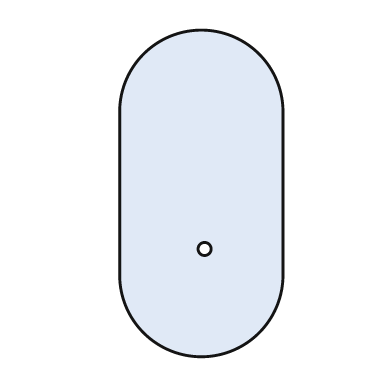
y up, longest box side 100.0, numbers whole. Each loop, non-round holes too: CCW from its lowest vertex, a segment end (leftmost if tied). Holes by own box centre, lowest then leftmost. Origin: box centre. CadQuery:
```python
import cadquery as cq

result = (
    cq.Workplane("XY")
    .moveTo(-25.0, -25.0)
    .threePointArc((0.0, -50.0), (25.0, -25.0))
    .lineTo(25.0, 25.0)
    .threePointArc((0.0, 50.0), (-25.0, 25.0))
    .close()
    .moveTo(1.0, -17.0)
    .circle(2.0)
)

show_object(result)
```